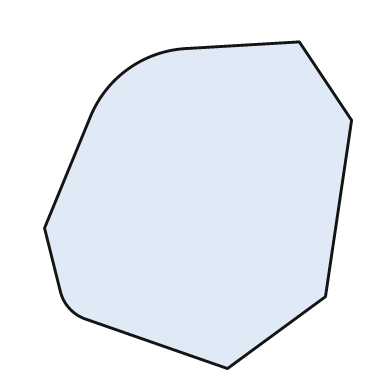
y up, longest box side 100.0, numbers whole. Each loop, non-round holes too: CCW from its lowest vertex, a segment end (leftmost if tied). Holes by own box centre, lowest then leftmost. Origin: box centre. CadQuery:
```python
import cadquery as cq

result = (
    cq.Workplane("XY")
    .moveTo(9.0, -50.0)
    .lineTo(39.0, -28.0)
    .lineTo(47.0, 26.0)
    .lineTo(31.0, 50.0)
    .lineTo(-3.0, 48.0)
    .threePointArc((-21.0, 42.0), (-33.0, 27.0))
    .lineTo(-47.0, -7.0)
    .lineTo(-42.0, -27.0)
    .threePointArc((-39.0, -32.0), (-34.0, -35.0))
    .close()
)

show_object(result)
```